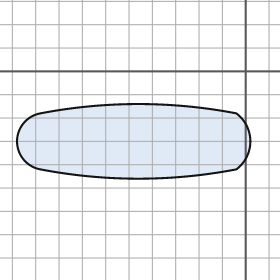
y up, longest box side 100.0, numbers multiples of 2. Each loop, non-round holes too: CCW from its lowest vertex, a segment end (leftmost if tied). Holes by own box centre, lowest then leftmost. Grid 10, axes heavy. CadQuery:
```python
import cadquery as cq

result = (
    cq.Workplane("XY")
    .moveTo(-88.0, -42.0)
    .threePointArc((-46.0, -46.0), (-4.0, -42.0))
    .threePointArc((2.0, -30.0), (-4.0, -18.0))
    .threePointArc((-46.0, -14.0), (-88.0, -18.0))
    .threePointArc((-98.0, -30.0), (-88.0, -42.0))
    .close()
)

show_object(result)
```